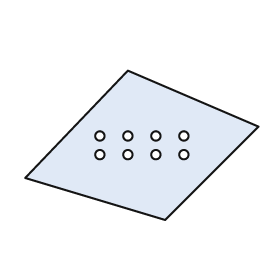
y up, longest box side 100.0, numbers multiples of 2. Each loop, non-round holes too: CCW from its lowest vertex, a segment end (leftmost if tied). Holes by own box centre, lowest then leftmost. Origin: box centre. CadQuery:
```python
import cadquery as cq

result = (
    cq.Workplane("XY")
    .moveTo(10.0, -32.0)
    .lineTo(50.0, 8.0)
    .lineTo(-6.0, 32.0)
    .lineTo(-50.0, -14.0)
    .close()
    .moveTo(-18.0, -4.0)
    .circle(2.0)
    .moveTo(-6.0, -4.0)
    .circle(2.0)
    .moveTo(6.0, -4.0)
    .circle(2.0)
    .moveTo(18.0, -4.0)
    .circle(2.0)
    .moveTo(-18.0, 4.0)
    .circle(2.0)
    .moveTo(-6.0, 4.0)
    .circle(2.0)
    .moveTo(6.0, 4.0)
    .circle(2.0)
    .moveTo(18.0, 4.0)
    .circle(2.0)
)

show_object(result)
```